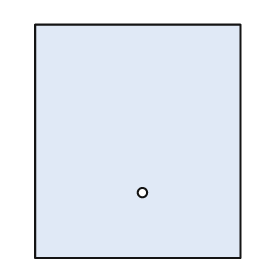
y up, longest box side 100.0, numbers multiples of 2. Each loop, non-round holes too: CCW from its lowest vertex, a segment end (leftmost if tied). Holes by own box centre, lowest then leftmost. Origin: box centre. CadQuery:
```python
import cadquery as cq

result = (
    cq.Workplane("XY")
    .moveTo(-44.0, -50.0)
    .lineTo(44.0, -50.0)
    .lineTo(44.0, 50.0)
    .lineTo(-44.0, 50.0)
    .close()
    .moveTo(2.0, -22.0)
    .circle(2.0)
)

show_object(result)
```